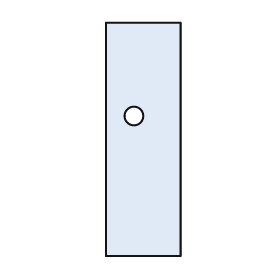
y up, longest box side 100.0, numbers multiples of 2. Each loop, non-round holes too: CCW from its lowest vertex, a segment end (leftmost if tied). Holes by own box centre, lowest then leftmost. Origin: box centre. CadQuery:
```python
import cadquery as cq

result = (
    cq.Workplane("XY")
    .moveTo(-16.0, -50.0)
    .lineTo(16.0, -50.0)
    .lineTo(16.0, 50.0)
    .lineTo(-16.0, 50.0)
    .close()
    .moveTo(-4.0, 10.0)
    .circle(4.0)
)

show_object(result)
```